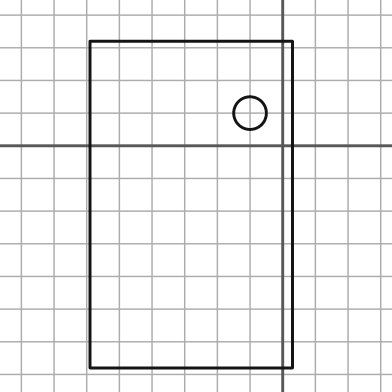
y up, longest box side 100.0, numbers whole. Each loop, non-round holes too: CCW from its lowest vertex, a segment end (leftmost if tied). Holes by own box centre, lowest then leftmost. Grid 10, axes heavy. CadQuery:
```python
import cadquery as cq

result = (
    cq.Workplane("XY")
    .moveTo(-59.0, -68.0)
    .lineTo(3.0, -68.0)
    .lineTo(3.0, 32.0)
    .lineTo(-59.0, 32.0)
    .close()
    .moveTo(-10.0, 10.0)
    .circle(5.0)
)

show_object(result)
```